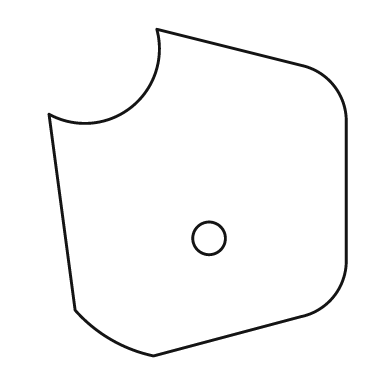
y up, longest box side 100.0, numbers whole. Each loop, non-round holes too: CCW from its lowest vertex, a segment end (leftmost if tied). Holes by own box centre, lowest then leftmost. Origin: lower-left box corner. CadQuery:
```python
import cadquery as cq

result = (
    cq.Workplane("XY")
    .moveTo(32.0, 0.0)
    .lineTo(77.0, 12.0)
    .threePointArc((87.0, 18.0), (91.0, 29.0))
    .lineTo(91.0, 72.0)
    .threePointArc((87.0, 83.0), (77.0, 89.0))
    .lineTo(33.0, 100.0)
    .threePointArc((25.0, 76.0), (0.0, 74.0))
    .lineTo(8.0, 14.0)
    .threePointArc((19.0, 5.0), (32.0, 0.0))
    .close()
    .moveTo(49.0, 36.0)
    .circle(5.0)
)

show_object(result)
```